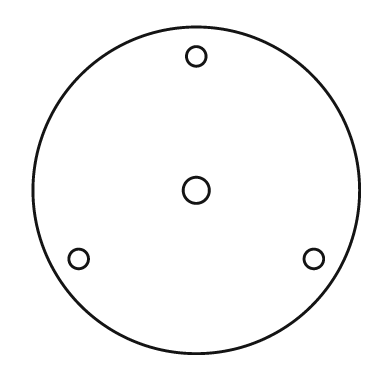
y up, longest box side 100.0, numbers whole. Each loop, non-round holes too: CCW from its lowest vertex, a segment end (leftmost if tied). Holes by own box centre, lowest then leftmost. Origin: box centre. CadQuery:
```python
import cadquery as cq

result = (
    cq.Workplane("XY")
    .moveTo(0.0, 0.0)
    .circle(50.0)
    .moveTo(-36.0, -21.0)
    .circle(3.0)
    .moveTo(36.0, -21.0)
    .circle(3.0)
    .moveTo(0.0, 0.0)
    .circle(4.0)
    .moveTo(0.0, 41.0)
    .circle(3.0)
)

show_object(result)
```